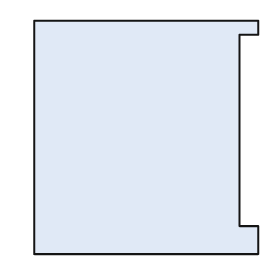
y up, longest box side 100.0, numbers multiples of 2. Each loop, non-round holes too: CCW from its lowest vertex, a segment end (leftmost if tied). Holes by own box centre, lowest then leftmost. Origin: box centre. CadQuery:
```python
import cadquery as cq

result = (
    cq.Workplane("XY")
    .moveTo(-48.0, -50.0)
    .lineTo(48.0, -50.0)
    .lineTo(48.0, -38.0)
    .lineTo(40.0, -38.0)
    .lineTo(40.0, 44.0)
    .lineTo(48.0, 44.0)
    .lineTo(48.0, 50.0)
    .lineTo(-48.0, 50.0)
    .close()
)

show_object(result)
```